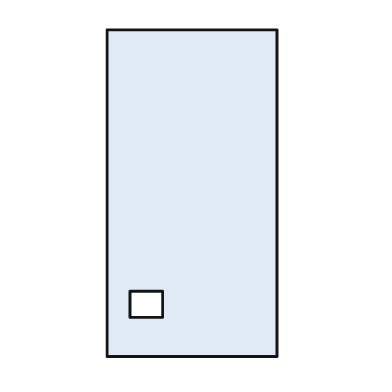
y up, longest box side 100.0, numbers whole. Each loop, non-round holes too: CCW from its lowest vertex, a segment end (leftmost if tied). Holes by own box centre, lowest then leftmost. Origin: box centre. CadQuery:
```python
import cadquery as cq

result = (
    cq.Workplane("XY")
    .moveTo(-26.0, -50.0)
    .lineTo(26.0, -50.0)
    .lineTo(26.0, 50.0)
    .lineTo(-26.0, 50.0)
    .close()
    .moveTo(-19.0, -38.0)
    .lineTo(-9.0, -38.0)
    .lineTo(-9.0, -30.0)
    .lineTo(-19.0, -30.0)
    .close()
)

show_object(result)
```